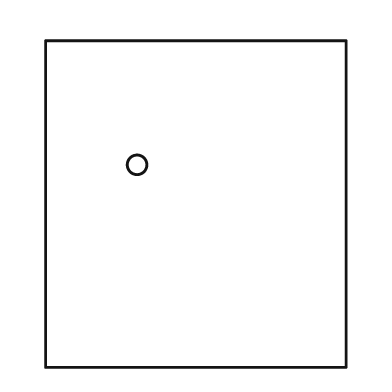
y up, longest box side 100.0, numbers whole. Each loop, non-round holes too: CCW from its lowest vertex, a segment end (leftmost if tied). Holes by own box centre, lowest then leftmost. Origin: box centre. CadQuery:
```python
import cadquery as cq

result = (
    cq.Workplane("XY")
    .moveTo(-46.0, -50.0)
    .lineTo(46.0, -50.0)
    .lineTo(46.0, 50.0)
    .lineTo(-46.0, 50.0)
    .close()
    .moveTo(-18.0, 12.0)
    .circle(3.0)
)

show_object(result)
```